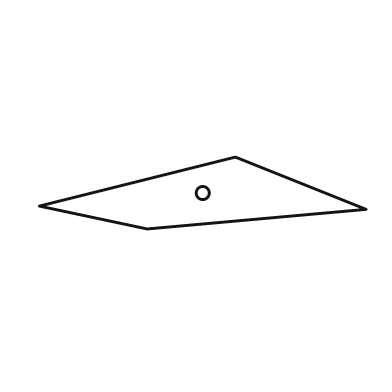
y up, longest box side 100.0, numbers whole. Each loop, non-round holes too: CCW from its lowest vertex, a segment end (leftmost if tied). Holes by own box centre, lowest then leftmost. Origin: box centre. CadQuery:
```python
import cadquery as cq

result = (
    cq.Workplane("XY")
    .moveTo(-17.0, -11.0)
    .lineTo(50.0, -5.0)
    .lineTo(10.0, 11.0)
    .lineTo(-50.0, -4.0)
    .close()
    .moveTo(0.0, 0.0)
    .circle(2.0)
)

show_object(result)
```